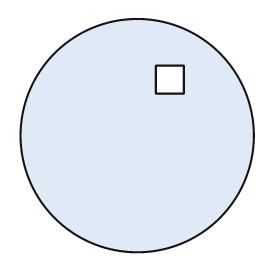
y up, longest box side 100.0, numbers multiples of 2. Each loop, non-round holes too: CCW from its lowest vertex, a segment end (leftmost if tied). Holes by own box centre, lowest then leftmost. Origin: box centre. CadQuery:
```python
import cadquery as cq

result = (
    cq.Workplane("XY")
    .moveTo(0.0, 0.0)
    .circle(50.0)
    .moveTo(8.0, 18.0)
    .lineTo(20.0, 18.0)
    .lineTo(20.0, 30.0)
    .lineTo(8.0, 30.0)
    .close()
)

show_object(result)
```